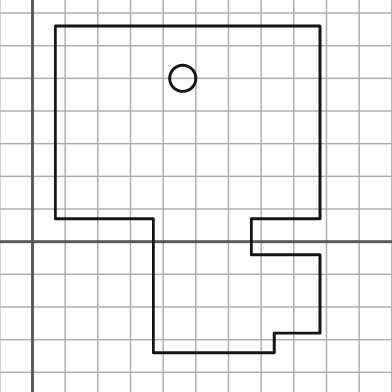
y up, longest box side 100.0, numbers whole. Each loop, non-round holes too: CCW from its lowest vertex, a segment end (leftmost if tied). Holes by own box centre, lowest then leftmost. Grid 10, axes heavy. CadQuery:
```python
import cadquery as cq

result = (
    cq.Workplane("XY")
    .moveTo(37.0, -34.0)
    .lineTo(74.0, -34.0)
    .lineTo(74.0, -28.0)
    .lineTo(88.0, -28.0)
    .lineTo(88.0, -4.0)
    .lineTo(67.0, -4.0)
    .lineTo(67.0, 7.0)
    .lineTo(88.0, 7.0)
    .lineTo(88.0, 66.0)
    .lineTo(7.0, 66.0)
    .lineTo(7.0, 7.0)
    .lineTo(37.0, 7.0)
    .close()
    .moveTo(46.0, 50.0)
    .circle(4.0)
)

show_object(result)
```